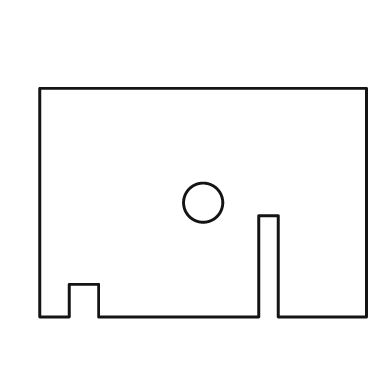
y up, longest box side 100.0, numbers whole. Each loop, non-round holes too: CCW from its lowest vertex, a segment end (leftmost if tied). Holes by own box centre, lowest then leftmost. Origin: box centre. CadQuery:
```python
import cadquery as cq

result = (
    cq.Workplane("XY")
    .moveTo(-50.0, -35.0)
    .lineTo(-41.0, -35.0)
    .lineTo(-41.0, -25.0)
    .lineTo(-32.0, -25.0)
    .lineTo(-32.0, -35.0)
    .lineTo(17.0, -35.0)
    .lineTo(17.0, -4.0)
    .lineTo(23.0, -4.0)
    .lineTo(23.0, -35.0)
    .lineTo(50.0, -35.0)
    .lineTo(50.0, 35.0)
    .lineTo(-50.0, 35.0)
    .close()
    .moveTo(0.0, 0.0)
    .circle(6.0)
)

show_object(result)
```